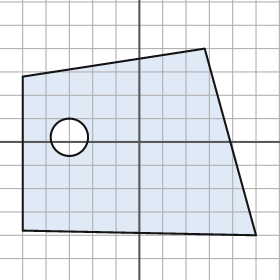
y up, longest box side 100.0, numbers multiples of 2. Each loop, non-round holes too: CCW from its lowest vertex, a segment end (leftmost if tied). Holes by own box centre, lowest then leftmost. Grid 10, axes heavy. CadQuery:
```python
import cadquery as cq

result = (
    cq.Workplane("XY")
    .moveTo(50.0, -40.0)
    .lineTo(28.0, 40.0)
    .lineTo(-50.0, 28.0)
    .lineTo(-50.0, -38.0)
    .close()
    .moveTo(-30.0, 2.0)
    .circle(8.0)
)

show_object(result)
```